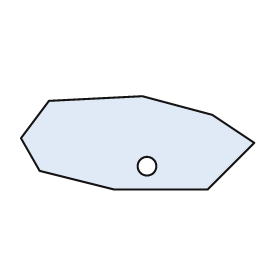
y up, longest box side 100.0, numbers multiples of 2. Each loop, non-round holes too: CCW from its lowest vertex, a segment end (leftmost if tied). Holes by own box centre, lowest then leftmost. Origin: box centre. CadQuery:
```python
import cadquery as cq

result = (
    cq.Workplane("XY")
    .moveTo(-10.0, -20.0)
    .lineTo(30.0, -20.0)
    .lineTo(50.0, 0.0)
    .lineTo(32.0, 12.0)
    .lineTo(2.0, 20.0)
    .lineTo(-38.0, 18.0)
    .lineTo(-50.0, 2.0)
    .lineTo(-42.0, -12.0)
    .close()
    .moveTo(4.0, -10.0)
    .circle(4.0)
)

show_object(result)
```